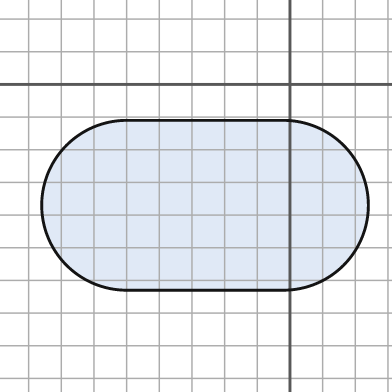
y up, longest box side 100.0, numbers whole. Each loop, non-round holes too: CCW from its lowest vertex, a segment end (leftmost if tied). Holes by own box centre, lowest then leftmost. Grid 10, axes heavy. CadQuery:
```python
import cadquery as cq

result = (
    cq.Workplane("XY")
    .moveTo(-50.0, -63.0)
    .lineTo(-2.0, -63.0)
    .threePointArc((24.0, -37.0), (-2.0, -11.0))
    .lineTo(-50.0, -11.0)
    .threePointArc((-76.0, -37.0), (-50.0, -63.0))
    .close()
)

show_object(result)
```